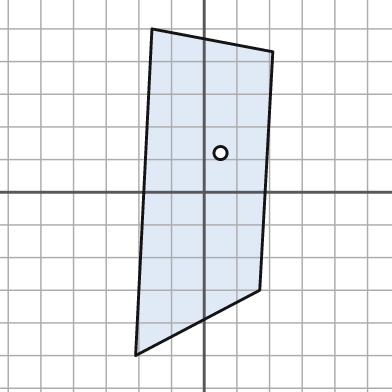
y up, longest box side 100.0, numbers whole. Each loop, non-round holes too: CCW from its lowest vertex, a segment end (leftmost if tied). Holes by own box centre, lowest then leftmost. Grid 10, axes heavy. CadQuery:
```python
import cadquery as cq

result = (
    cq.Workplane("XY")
    .moveTo(-21.0, -50.0)
    .lineTo(17.0, -30.0)
    .lineTo(21.0, 43.0)
    .lineTo(-16.0, 50.0)
    .close()
    .moveTo(5.0, 12.0)
    .circle(2.0)
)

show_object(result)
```